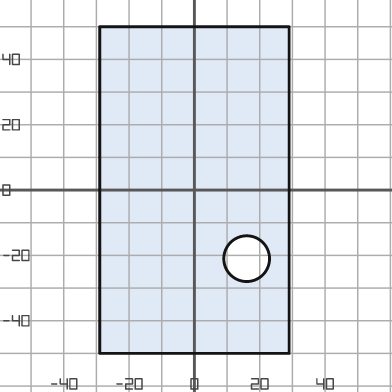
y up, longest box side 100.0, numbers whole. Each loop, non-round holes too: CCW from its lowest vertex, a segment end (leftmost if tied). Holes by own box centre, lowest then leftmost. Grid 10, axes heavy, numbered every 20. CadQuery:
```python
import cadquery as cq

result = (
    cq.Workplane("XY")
    .moveTo(-29.0, -50.0)
    .lineTo(29.0, -50.0)
    .lineTo(29.0, 50.0)
    .lineTo(-29.0, 50.0)
    .close()
    .moveTo(16.0, -21.0)
    .circle(7.0)
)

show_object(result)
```